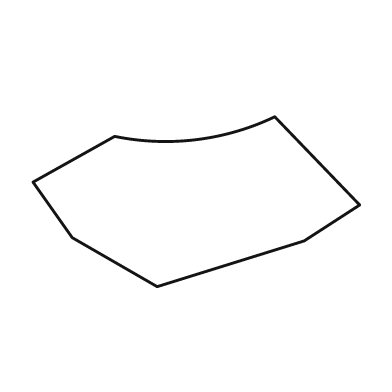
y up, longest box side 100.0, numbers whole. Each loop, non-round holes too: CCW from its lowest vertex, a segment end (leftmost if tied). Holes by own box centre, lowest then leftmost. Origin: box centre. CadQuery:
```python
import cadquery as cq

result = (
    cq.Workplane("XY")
    .moveTo(-12.0, -26.0)
    .lineTo(33.0, -12.0)
    .lineTo(50.0, -1.0)
    .lineTo(24.0, 26.0)
    .threePointArc((0.0, 19.0), (-25.0, 20.0))
    .lineTo(-50.0, 6.0)
    .lineTo(-38.0, -11.0)
    .close()
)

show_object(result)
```